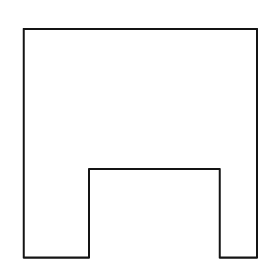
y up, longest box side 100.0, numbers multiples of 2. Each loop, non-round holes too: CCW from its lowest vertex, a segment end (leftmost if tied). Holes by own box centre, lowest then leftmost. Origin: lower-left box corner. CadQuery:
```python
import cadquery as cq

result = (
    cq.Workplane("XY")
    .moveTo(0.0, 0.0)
    .lineTo(28.0, 0.0)
    .lineTo(28.0, 38.0)
    .lineTo(84.0, 38.0)
    .lineTo(84.0, 0.0)
    .lineTo(100.0, 0.0)
    .lineTo(100.0, 98.0)
    .lineTo(0.0, 98.0)
    .close()
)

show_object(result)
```